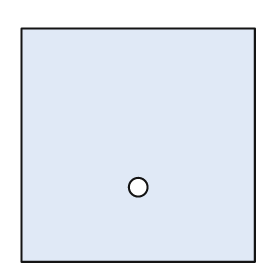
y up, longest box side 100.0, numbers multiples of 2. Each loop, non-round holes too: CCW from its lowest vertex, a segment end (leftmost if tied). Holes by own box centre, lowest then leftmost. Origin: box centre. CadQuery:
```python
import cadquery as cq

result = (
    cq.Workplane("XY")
    .moveTo(-50.0, -50.0)
    .lineTo(50.0, -50.0)
    .lineTo(50.0, 50.0)
    .lineTo(-50.0, 50.0)
    .close()
    .moveTo(0.0, -18.0)
    .circle(4.0)
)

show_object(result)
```